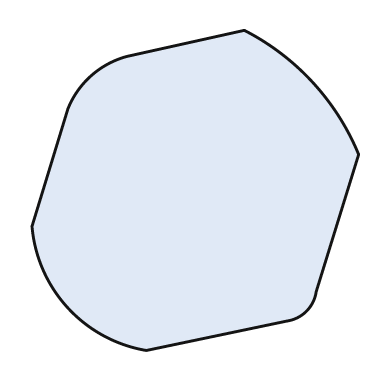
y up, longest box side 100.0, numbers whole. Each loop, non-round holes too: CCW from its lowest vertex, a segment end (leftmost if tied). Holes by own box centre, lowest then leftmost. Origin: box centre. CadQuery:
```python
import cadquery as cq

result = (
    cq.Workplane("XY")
    .moveTo(-15.0, -49.0)
    .lineTo(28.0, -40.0)
    .threePointArc((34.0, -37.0), (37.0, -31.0))
    .lineTo(50.0, 11.0)
    .threePointArc((36.0, 33.0), (15.0, 49.0))
    .lineTo(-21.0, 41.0)
    .threePointArc((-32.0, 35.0), (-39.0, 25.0))
    .lineTo(-50.0, -11.0)
    .threePointArc((-39.0, -36.0), (-15.0, -49.0))
    .close()
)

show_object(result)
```